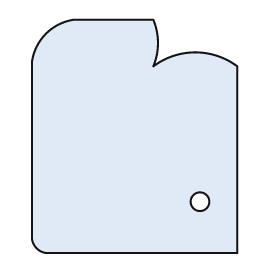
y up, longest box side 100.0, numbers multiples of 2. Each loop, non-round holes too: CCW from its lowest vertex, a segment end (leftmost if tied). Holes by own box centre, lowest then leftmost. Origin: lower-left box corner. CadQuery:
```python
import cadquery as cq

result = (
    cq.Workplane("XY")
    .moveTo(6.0, 0.0)
    .lineTo(88.0, 0.0)
    .lineTo(88.0, 80.0)
    .threePointArc((70.0, 86.0), (52.0, 80.0))
    .threePointArc((54.0, 90.0), (52.0, 100.0))
    .lineTo(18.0, 100.0)
    .threePointArc((6.0, 94.0), (0.0, 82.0))
    .lineTo(0.0, 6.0)
    .threePointArc((2.0, 2.0), (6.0, 0.0))
    .close()
    .moveTo(72.0, 22.0)
    .circle(4.0)
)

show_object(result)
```